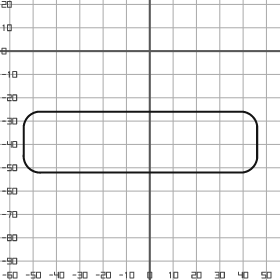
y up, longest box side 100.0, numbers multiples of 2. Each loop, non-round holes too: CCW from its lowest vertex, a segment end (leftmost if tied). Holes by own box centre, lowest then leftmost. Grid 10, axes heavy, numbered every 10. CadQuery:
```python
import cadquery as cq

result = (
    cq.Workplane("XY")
    .moveTo(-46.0, -52.0)
    .lineTo(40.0, -52.0)
    .threePointArc((44.0, -50.0), (46.0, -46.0))
    .lineTo(46.0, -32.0)
    .threePointArc((44.0, -28.0), (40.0, -26.0))
    .lineTo(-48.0, -26.0)
    .threePointArc((-52.0, -28.0), (-54.0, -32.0))
    .lineTo(-54.0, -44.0)
    .threePointArc((-52.0, -50.0), (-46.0, -52.0))
    .close()
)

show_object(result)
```